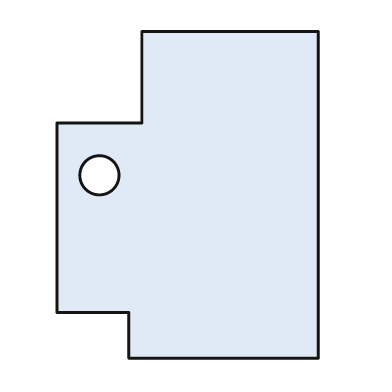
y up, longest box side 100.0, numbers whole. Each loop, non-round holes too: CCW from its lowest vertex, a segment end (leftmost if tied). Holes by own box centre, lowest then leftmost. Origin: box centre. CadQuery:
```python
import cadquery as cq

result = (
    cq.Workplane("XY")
    .moveTo(-18.0, -50.0)
    .lineTo(40.0, -50.0)
    .lineTo(40.0, 50.0)
    .lineTo(-14.0, 50.0)
    .lineTo(-14.0, 22.0)
    .lineTo(-40.0, 22.0)
    .lineTo(-40.0, -36.0)
    .lineTo(-18.0, -36.0)
    .close()
    .moveTo(-27.0, 6.0)
    .circle(6.0)
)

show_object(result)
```